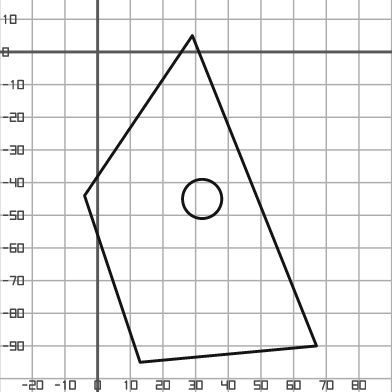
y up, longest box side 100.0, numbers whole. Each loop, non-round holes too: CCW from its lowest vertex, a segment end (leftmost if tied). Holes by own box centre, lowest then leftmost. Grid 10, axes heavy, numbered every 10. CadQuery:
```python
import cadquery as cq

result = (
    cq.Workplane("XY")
    .moveTo(13.0, -95.0)
    .lineTo(67.0, -90.0)
    .lineTo(29.0, 5.0)
    .lineTo(-4.0, -44.0)
    .close()
    .moveTo(32.0, -45.0)
    .circle(6.0)
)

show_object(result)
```